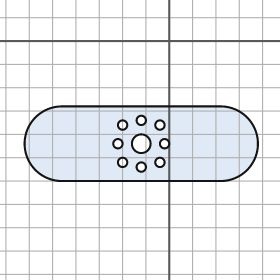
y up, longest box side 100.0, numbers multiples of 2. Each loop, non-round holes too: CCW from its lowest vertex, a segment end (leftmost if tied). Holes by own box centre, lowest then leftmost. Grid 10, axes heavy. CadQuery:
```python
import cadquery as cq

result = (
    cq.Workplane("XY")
    .moveTo(-46.0, -60.0)
    .lineTo(22.0, -60.0)
    .threePointArc((38.0, -44.0), (22.0, -28.0))
    .lineTo(-46.0, -28.0)
    .threePointArc((-62.0, -44.0), (-46.0, -60.0))
    .close()
    .moveTo(-12.0, -54.0)
    .circle(2.0)
    .moveTo(-20.0, -52.0)
    .circle(2.0)
    .moveTo(-4.0, -52.0)
    .circle(2.0)
    .moveTo(-22.0, -44.0)
    .circle(2.0)
    .moveTo(-12.0, -44.0)
    .circle(4.0)
    .moveTo(-2.0, -44.0)
    .circle(2.0)
    .moveTo(-20.0, -36.0)
    .circle(2.0)
    .moveTo(-4.0, -36.0)
    .circle(2.0)
    .moveTo(-12.0, -34.0)
    .circle(2.0)
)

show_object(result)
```